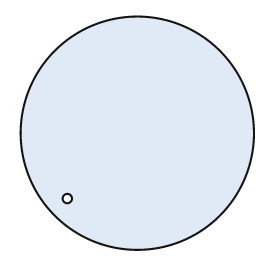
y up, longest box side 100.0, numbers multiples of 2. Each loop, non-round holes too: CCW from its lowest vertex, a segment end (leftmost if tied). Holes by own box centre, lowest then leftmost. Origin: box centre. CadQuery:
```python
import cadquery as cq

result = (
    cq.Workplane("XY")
    .moveTo(0.0, 0.0)
    .circle(50.0)
    .moveTo(-30.0, -28.0)
    .circle(2.0)
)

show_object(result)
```